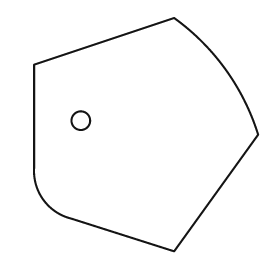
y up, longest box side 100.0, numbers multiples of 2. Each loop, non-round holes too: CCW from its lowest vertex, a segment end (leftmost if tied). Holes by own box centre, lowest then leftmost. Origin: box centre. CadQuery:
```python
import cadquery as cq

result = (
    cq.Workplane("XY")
    .moveTo(12.0, -50.0)
    .lineTo(48.0, 0.0)
    .threePointArc((34.0, 28.0), (12.0, 50.0))
    .lineTo(-48.0, 30.0)
    .lineTo(-48.0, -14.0)
    .threePointArc((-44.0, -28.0), (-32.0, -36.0))
    .close()
    .moveTo(-28.0, 6.0)
    .circle(4.0)
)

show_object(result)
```